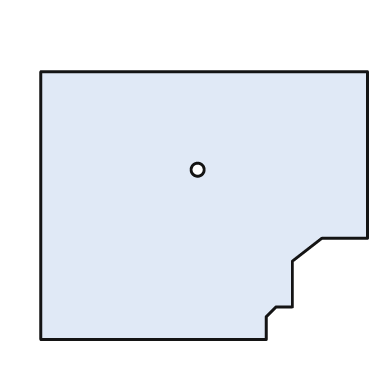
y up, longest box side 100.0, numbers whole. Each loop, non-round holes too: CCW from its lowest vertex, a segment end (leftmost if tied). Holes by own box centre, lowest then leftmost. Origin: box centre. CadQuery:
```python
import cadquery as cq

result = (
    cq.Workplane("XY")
    .moveTo(-50.0, -41.0)
    .lineTo(19.0, -41.0)
    .lineTo(19.0, -34.0)
    .lineTo(22.0, -31.0)
    .lineTo(27.0, -31.0)
    .lineTo(27.0, -17.0)
    .lineTo(36.0, -10.0)
    .lineTo(50.0, -10.0)
    .lineTo(50.0, 41.0)
    .lineTo(-50.0, 41.0)
    .close()
    .moveTo(-2.0, 11.0)
    .circle(2.0)
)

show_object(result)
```